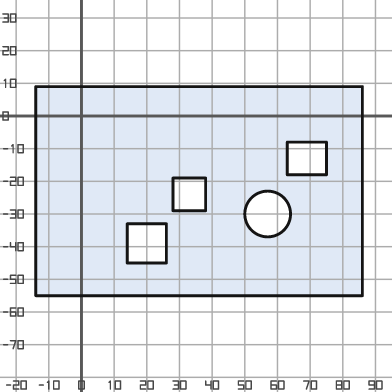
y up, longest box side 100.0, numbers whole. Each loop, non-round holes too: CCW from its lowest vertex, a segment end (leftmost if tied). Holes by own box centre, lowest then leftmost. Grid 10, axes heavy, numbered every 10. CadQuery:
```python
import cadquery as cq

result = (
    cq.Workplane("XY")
    .moveTo(-14.0, -55.0)
    .lineTo(86.0, -55.0)
    .lineTo(86.0, 9.0)
    .lineTo(-14.0, 9.0)
    .close()
    .moveTo(14.0, -45.0)
    .lineTo(26.0, -45.0)
    .lineTo(26.0, -33.0)
    .lineTo(14.0, -33.0)
    .close()
    .moveTo(57.0, -30.0)
    .circle(7.0)
    .moveTo(28.0, -29.0)
    .lineTo(38.0, -29.0)
    .lineTo(38.0, -19.0)
    .lineTo(28.0, -19.0)
    .close()
    .moveTo(63.0, -18.0)
    .lineTo(75.0, -18.0)
    .lineTo(75.0, -8.0)
    .lineTo(63.0, -8.0)
    .close()
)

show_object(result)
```